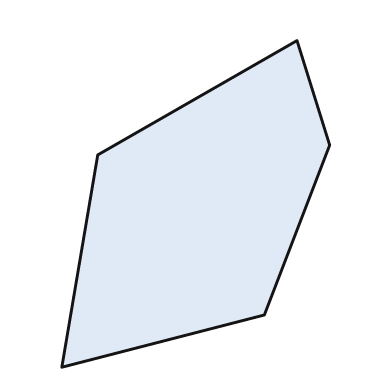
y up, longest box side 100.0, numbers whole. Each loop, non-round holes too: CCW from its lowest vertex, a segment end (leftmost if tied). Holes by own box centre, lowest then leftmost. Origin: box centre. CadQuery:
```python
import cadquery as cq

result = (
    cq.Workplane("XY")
    .moveTo(-41.0, -50.0)
    .lineTo(21.0, -34.0)
    .lineTo(41.0, 18.0)
    .lineTo(31.0, 50.0)
    .lineTo(-30.0, 15.0)
    .close()
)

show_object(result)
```